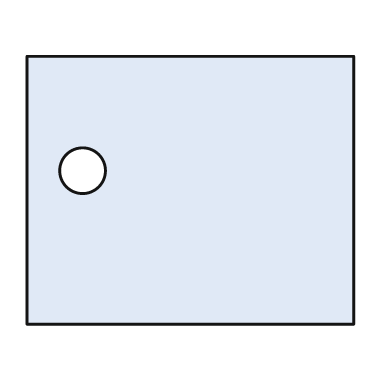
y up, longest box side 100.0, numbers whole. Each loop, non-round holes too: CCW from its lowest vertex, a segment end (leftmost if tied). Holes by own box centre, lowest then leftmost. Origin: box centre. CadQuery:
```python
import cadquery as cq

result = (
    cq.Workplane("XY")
    .moveTo(-50.0, -41.0)
    .lineTo(50.0, -41.0)
    .lineTo(50.0, 41.0)
    .lineTo(-50.0, 41.0)
    .close()
    .moveTo(-33.0, 6.0)
    .circle(7.0)
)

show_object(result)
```